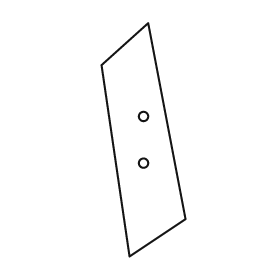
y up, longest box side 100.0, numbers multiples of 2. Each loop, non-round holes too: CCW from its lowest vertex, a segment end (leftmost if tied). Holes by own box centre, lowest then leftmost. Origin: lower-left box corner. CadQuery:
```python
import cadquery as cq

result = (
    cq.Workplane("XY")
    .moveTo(12.0, 0.0)
    .lineTo(36.0, 16.0)
    .lineTo(20.0, 100.0)
    .lineTo(0.0, 82.0)
    .close()
    .moveTo(18.0, 40.0)
    .circle(2.0)
    .moveTo(18.0, 60.0)
    .circle(2.0)
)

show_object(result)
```